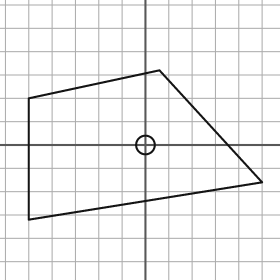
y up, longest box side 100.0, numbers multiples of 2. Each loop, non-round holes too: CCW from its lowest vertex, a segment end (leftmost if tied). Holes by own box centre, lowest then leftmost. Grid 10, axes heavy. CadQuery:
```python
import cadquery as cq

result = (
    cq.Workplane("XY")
    .moveTo(-50.0, -32.0)
    .lineTo(50.0, -16.0)
    .lineTo(6.0, 32.0)
    .lineTo(-50.0, 20.0)
    .close()
    .moveTo(0.0, 0.0)
    .circle(4.0)
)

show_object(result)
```